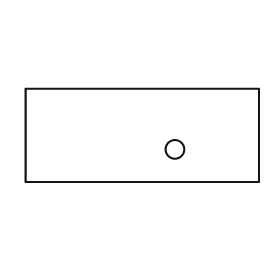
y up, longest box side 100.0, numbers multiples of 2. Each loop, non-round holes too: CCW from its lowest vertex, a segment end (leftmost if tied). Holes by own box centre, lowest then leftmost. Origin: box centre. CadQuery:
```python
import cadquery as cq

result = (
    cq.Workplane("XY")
    .moveTo(-50.0, -20.0)
    .lineTo(50.0, -20.0)
    .lineTo(50.0, 20.0)
    .lineTo(-50.0, 20.0)
    .close()
    .moveTo(14.0, -6.0)
    .circle(4.0)
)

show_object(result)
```